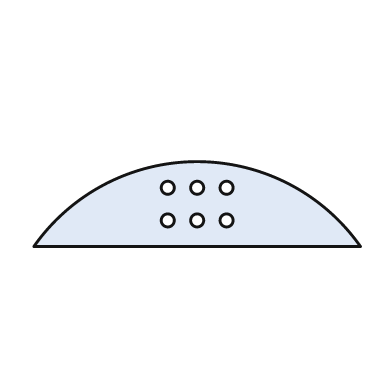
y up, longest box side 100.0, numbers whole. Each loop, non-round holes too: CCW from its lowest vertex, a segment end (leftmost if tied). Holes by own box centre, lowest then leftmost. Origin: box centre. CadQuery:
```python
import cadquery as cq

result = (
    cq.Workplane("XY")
    .moveTo(-50.0, -13.0)
    .lineTo(50.0, -13.0)
    .threePointArc((0.0, 13.0), (-50.0, -13.0))
    .close()
    .moveTo(-9.0, -5.0)
    .circle(2.0)
    .moveTo(0.0, -5.0)
    .circle(2.0)
    .moveTo(9.0, -5.0)
    .circle(2.0)
    .moveTo(-9.0, 5.0)
    .circle(2.0)
    .moveTo(0.0, 5.0)
    .circle(2.0)
    .moveTo(9.0, 5.0)
    .circle(2.0)
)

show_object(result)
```